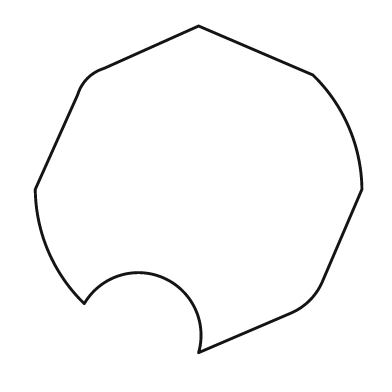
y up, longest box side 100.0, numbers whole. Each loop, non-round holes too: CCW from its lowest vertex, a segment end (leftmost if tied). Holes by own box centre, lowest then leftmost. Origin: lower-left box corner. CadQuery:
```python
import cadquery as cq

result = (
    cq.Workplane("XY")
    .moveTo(50.0, 0.0)
    .lineTo(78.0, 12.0)
    .threePointArc((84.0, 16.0), (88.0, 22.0))
    .lineTo(100.0, 50.0)
    .threePointArc((96.0, 69.0), (85.0, 85.0))
    .lineTo(50.0, 100.0)
    .lineTo(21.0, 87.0)
    .threePointArc((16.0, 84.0), (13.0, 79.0))
    .lineTo(0.0, 50.0)
    .threePointArc((4.0, 31.0), (15.0, 15.0))
    .threePointArc((39.0, 23.0), (50.0, 0.0))
    .close()
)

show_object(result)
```